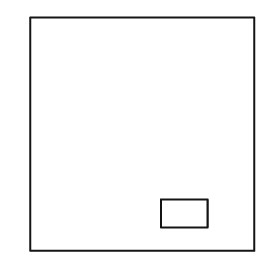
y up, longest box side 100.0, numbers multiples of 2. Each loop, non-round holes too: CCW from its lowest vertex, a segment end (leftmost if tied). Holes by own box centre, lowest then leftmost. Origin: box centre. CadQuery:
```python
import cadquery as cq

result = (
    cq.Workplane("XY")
    .moveTo(-48.0, -50.0)
    .lineTo(48.0, -50.0)
    .lineTo(48.0, 50.0)
    .lineTo(-48.0, 50.0)
    .close()
    .moveTo(8.0, -40.0)
    .lineTo(28.0, -40.0)
    .lineTo(28.0, -28.0)
    .lineTo(8.0, -28.0)
    .close()
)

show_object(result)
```